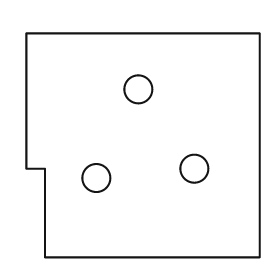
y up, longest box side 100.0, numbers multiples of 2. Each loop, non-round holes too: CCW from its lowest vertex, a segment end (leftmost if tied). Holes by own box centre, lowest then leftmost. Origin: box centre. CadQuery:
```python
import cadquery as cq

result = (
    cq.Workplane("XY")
    .moveTo(-42.0, -48.0)
    .lineTo(50.0, -48.0)
    .lineTo(50.0, 48.0)
    .lineTo(-50.0, 48.0)
    .lineTo(-50.0, -10.0)
    .lineTo(-42.0, -10.0)
    .close()
    .moveTo(-20.0, -14.0)
    .circle(6.0)
    .moveTo(22.0, -10.0)
    .circle(6.0)
    .moveTo(-2.0, 24.0)
    .circle(6.0)
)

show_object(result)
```